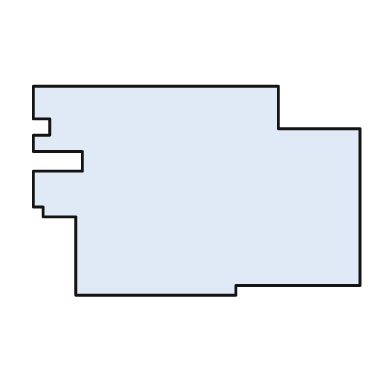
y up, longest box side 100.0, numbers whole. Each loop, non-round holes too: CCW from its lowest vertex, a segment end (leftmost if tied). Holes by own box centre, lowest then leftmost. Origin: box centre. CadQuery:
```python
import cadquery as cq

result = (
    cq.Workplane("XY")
    .moveTo(-37.0, -32.0)
    .lineTo(12.0, -32.0)
    .lineTo(12.0, -29.0)
    .lineTo(50.0, -29.0)
    .lineTo(50.0, 19.0)
    .lineTo(25.0, 19.0)
    .lineTo(25.0, 32.0)
    .lineTo(-50.0, 32.0)
    .lineTo(-50.0, 22.0)
    .lineTo(-45.0, 22.0)
    .lineTo(-45.0, 17.0)
    .lineTo(-50.0, 17.0)
    .lineTo(-50.0, 12.0)
    .lineTo(-35.0, 12.0)
    .lineTo(-35.0, 6.0)
    .lineTo(-50.0, 6.0)
    .lineTo(-50.0, -5.0)
    .lineTo(-47.0, -5.0)
    .lineTo(-47.0, -8.0)
    .lineTo(-37.0, -8.0)
    .close()
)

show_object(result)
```